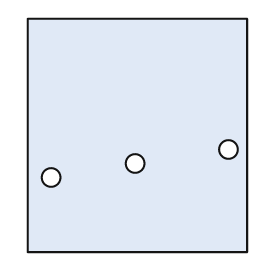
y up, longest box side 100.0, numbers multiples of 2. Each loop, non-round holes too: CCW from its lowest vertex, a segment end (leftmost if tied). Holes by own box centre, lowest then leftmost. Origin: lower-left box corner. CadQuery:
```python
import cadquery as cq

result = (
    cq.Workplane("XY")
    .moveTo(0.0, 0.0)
    .lineTo(94.0, 0.0)
    .lineTo(94.0, 100.0)
    .lineTo(0.0, 100.0)
    .close()
    .moveTo(10.0, 32.0)
    .circle(4.0)
    .moveTo(46.0, 38.0)
    .circle(4.0)
    .moveTo(86.0, 44.0)
    .circle(4.0)
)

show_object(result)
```